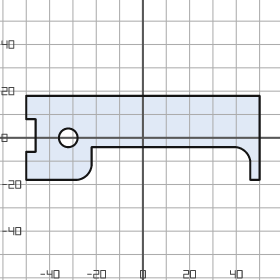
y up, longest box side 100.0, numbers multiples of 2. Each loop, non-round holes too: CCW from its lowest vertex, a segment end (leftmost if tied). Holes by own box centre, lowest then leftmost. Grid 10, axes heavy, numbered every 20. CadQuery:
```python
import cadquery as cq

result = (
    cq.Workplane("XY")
    .moveTo(-50.0, -18.0)
    .lineTo(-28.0, -18.0)
    .threePointArc((-24.0, -16.0), (-22.0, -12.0))
    .lineTo(-22.0, -4.0)
    .lineTo(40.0, -4.0)
    .threePointArc((44.0, -6.0), (46.0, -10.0))
    .lineTo(46.0, -18.0)
    .lineTo(50.0, -18.0)
    .lineTo(50.0, 18.0)
    .lineTo(-50.0, 18.0)
    .lineTo(-50.0, 8.0)
    .lineTo(-46.0, 8.0)
    .lineTo(-46.0, -6.0)
    .lineTo(-50.0, -6.0)
    .close()
    .moveTo(-32.0, 0.0)
    .circle(4.0)
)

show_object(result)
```